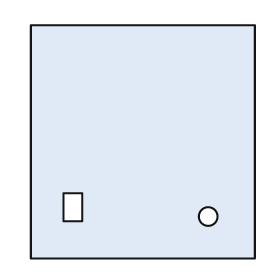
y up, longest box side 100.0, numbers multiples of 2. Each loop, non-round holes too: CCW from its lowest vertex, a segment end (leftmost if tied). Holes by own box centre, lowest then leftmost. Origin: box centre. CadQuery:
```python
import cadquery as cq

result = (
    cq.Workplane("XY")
    .moveTo(-48.0, -50.0)
    .lineTo(48.0, -50.0)
    .lineTo(48.0, 50.0)
    .lineTo(-48.0, 50.0)
    .close()
    .moveTo(28.0, -32.0)
    .circle(4.0)
    .moveTo(-34.0, -34.0)
    .lineTo(-26.0, -34.0)
    .lineTo(-26.0, -22.0)
    .lineTo(-34.0, -22.0)
    .close()
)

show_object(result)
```